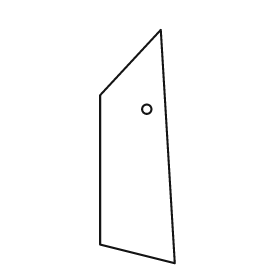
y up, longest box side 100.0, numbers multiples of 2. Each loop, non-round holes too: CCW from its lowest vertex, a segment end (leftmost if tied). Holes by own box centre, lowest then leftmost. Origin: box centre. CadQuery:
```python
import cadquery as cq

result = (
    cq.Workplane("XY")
    .moveTo(16.0, -50.0)
    .lineTo(10.0, 50.0)
    .lineTo(-16.0, 22.0)
    .lineTo(-16.0, -42.0)
    .close()
    .moveTo(4.0, 16.0)
    .circle(2.0)
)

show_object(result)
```